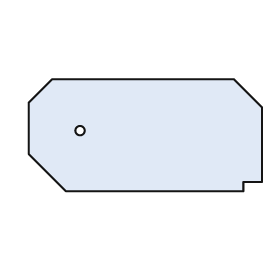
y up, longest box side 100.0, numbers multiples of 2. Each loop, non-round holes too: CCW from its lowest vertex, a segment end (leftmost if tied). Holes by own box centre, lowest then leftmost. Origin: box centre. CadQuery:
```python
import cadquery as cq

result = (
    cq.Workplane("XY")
    .moveTo(-34.0, -24.0)
    .lineTo(42.0, -24.0)
    .lineTo(42.0, -20.0)
    .lineTo(50.0, -20.0)
    .lineTo(50.0, 12.0)
    .lineTo(38.0, 24.0)
    .lineTo(-40.0, 24.0)
    .lineTo(-50.0, 14.0)
    .lineTo(-50.0, -8.0)
    .close()
    .moveTo(-28.0, 2.0)
    .circle(2.0)
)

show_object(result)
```